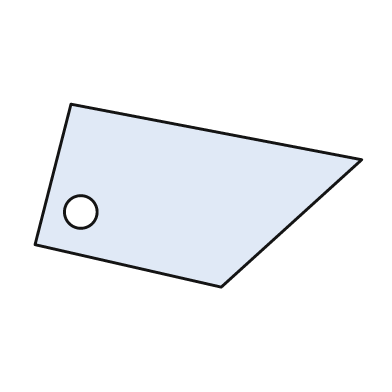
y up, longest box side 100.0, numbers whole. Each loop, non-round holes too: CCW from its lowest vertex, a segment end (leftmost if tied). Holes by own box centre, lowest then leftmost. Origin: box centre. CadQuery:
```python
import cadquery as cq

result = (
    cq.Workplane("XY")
    .moveTo(7.0, -28.0)
    .lineTo(50.0, 11.0)
    .lineTo(-39.0, 28.0)
    .lineTo(-50.0, -15.0)
    .close()
    .moveTo(-36.0, -5.0)
    .circle(5.0)
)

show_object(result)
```